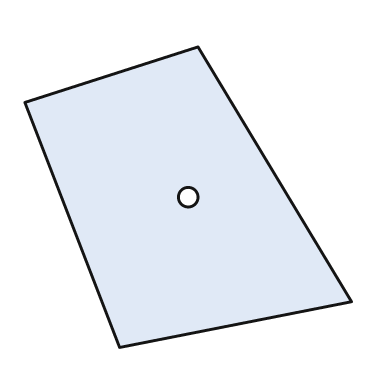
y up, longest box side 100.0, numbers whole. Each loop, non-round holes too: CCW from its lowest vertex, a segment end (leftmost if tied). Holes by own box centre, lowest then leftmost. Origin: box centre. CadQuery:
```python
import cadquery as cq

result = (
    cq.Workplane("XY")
    .moveTo(-21.0, -46.0)
    .lineTo(50.0, -32.0)
    .lineTo(3.0, 46.0)
    .lineTo(-50.0, 29.0)
    .close()
    .moveTo(0.0, 0.0)
    .circle(3.0)
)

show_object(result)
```